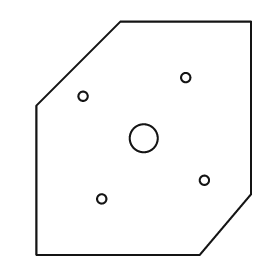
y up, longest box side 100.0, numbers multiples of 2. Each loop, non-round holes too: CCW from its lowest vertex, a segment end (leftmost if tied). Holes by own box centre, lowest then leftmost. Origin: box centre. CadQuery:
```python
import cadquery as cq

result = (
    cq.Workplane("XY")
    .moveTo(-46.0, -50.0)
    .lineTo(24.0, -50.0)
    .lineTo(46.0, -24.0)
    .lineTo(46.0, 50.0)
    .lineTo(-10.0, 50.0)
    .lineTo(-46.0, 14.0)
    .close()
    .moveTo(-18.0, -26.0)
    .circle(2.0)
    .moveTo(26.0, -18.0)
    .circle(2.0)
    .moveTo(0.0, 0.0)
    .circle(6.0)
    .moveTo(-26.0, 18.0)
    .circle(2.0)
    .moveTo(18.0, 26.0)
    .circle(2.0)
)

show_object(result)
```